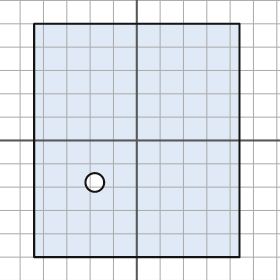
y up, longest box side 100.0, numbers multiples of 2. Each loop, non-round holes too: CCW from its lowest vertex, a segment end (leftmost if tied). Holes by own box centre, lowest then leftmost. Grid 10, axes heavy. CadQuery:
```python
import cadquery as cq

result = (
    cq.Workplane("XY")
    .moveTo(-44.0, -50.0)
    .lineTo(44.0, -50.0)
    .lineTo(44.0, 50.0)
    .lineTo(-44.0, 50.0)
    .close()
    .moveTo(-18.0, -18.0)
    .circle(4.0)
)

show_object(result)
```